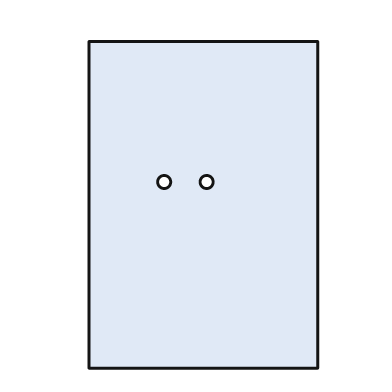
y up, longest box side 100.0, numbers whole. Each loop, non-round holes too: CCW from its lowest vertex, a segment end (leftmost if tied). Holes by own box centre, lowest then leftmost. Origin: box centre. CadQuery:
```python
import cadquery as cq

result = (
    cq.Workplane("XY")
    .moveTo(-35.0, -50.0)
    .lineTo(35.0, -50.0)
    .lineTo(35.0, 50.0)
    .lineTo(-35.0, 50.0)
    .close()
    .moveTo(-12.0, 7.0)
    .circle(2.0)
    .moveTo(1.0, 7.0)
    .circle(2.0)
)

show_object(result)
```